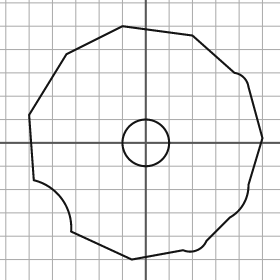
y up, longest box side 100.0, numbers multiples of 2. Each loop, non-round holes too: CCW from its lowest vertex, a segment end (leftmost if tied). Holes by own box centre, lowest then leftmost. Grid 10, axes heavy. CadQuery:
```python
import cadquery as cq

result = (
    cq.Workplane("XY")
    .moveTo(-6.0, -50.0)
    .lineTo(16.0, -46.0)
    .threePointArc((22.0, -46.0), (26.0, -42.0))
    .lineTo(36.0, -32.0)
    .threePointArc((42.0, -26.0), (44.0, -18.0))
    .lineTo(50.0, 2.0)
    .lineTo(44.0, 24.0)
    .threePointArc((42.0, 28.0), (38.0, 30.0))
    .lineTo(20.0, 46.0)
    .lineTo(-10.0, 50.0)
    .lineTo(-34.0, 38.0)
    .lineTo(-50.0, 12.0)
    .lineTo(-48.0, -16.0)
    .threePointArc((-36.0, -24.0), (-32.0, -38.0))
    .close()
    .moveTo(0.0, 0.0)
    .circle(10.0)
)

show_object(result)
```